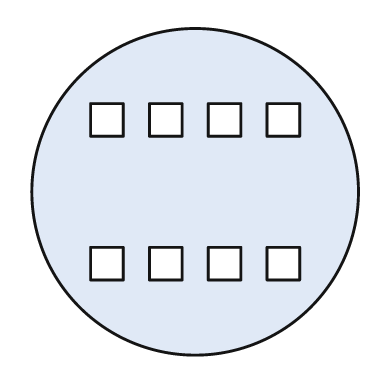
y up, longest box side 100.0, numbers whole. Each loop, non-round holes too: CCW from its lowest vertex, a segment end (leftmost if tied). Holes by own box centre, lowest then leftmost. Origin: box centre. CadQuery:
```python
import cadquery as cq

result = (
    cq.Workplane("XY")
    .moveTo(0.0, 0.0)
    .circle(50.0)
    .moveTo(-32.0, -27.0)
    .lineTo(-22.0, -27.0)
    .lineTo(-22.0, -17.0)
    .lineTo(-32.0, -17.0)
    .close()
    .moveTo(-14.0, -27.0)
    .lineTo(-4.0, -27.0)
    .lineTo(-4.0, -17.0)
    .lineTo(-14.0, -17.0)
    .close()
    .moveTo(4.0, -27.0)
    .lineTo(14.0, -27.0)
    .lineTo(14.0, -17.0)
    .lineTo(4.0, -17.0)
    .close()
    .moveTo(22.0, -27.0)
    .lineTo(32.0, -27.0)
    .lineTo(32.0, -17.0)
    .lineTo(22.0, -17.0)
    .close()
    .moveTo(-32.0, 17.0)
    .lineTo(-22.0, 17.0)
    .lineTo(-22.0, 27.0)
    .lineTo(-32.0, 27.0)
    .close()
    .moveTo(-14.0, 17.0)
    .lineTo(-4.0, 17.0)
    .lineTo(-4.0, 27.0)
    .lineTo(-14.0, 27.0)
    .close()
    .moveTo(4.0, 17.0)
    .lineTo(14.0, 17.0)
    .lineTo(14.0, 27.0)
    .lineTo(4.0, 27.0)
    .close()
    .moveTo(22.0, 17.0)
    .lineTo(32.0, 17.0)
    .lineTo(32.0, 27.0)
    .lineTo(22.0, 27.0)
    .close()
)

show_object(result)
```